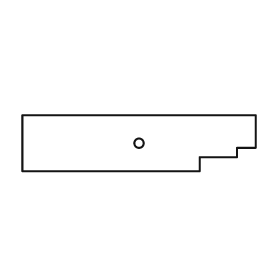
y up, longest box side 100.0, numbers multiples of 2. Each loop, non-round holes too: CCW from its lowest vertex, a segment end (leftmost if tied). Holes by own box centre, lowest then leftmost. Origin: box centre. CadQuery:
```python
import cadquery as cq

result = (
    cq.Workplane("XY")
    .moveTo(-50.0, -12.0)
    .lineTo(26.0, -12.0)
    .lineTo(26.0, -6.0)
    .lineTo(42.0, -6.0)
    .lineTo(42.0, -2.0)
    .lineTo(50.0, -2.0)
    .lineTo(50.0, 12.0)
    .lineTo(-50.0, 12.0)
    .close()
    .moveTo(0.0, 0.0)
    .circle(2.0)
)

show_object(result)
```